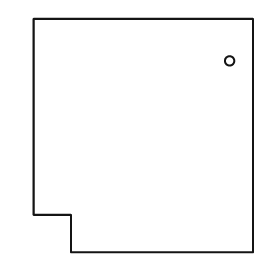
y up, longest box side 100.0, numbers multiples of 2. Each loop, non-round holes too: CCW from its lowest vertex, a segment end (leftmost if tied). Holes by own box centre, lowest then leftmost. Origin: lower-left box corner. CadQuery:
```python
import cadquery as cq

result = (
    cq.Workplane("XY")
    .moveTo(16.0, 0.0)
    .lineTo(94.0, 0.0)
    .lineTo(94.0, 100.0)
    .lineTo(0.0, 100.0)
    .lineTo(0.0, 16.0)
    .lineTo(16.0, 16.0)
    .close()
    .moveTo(84.0, 82.0)
    .circle(2.0)
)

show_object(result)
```